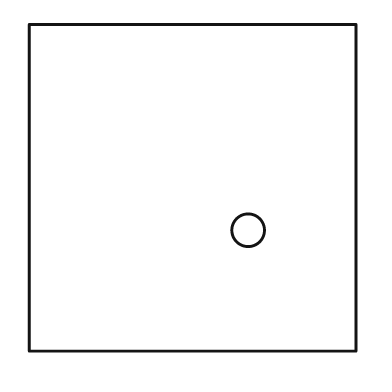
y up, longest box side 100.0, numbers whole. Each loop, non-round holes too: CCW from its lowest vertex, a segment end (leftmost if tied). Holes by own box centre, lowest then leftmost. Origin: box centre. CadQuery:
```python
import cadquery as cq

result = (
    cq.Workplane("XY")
    .moveTo(-50.0, -50.0)
    .lineTo(50.0, -50.0)
    .lineTo(50.0, 50.0)
    .lineTo(-50.0, 50.0)
    .close()
    .moveTo(17.0, -13.0)
    .circle(5.0)
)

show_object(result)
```